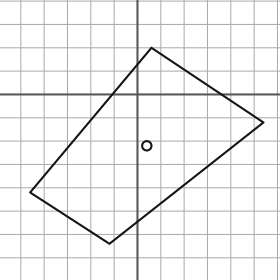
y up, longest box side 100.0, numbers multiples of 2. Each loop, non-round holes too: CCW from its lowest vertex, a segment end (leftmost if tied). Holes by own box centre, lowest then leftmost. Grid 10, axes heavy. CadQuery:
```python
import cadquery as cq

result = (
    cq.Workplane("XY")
    .moveTo(-12.0, -64.0)
    .lineTo(54.0, -12.0)
    .lineTo(6.0, 20.0)
    .lineTo(-46.0, -42.0)
    .close()
    .moveTo(4.0, -22.0)
    .circle(2.0)
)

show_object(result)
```